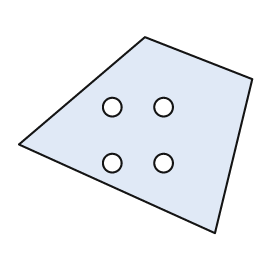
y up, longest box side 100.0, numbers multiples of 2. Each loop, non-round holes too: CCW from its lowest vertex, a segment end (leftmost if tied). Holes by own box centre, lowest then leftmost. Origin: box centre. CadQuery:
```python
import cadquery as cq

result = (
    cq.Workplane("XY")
    .moveTo(34.0, -42.0)
    .lineTo(50.0, 24.0)
    .lineTo(4.0, 42.0)
    .lineTo(-50.0, -4.0)
    .close()
    .moveTo(-10.0, -12.0)
    .circle(4.0)
    .moveTo(12.0, -12.0)
    .circle(4.0)
    .moveTo(-10.0, 12.0)
    .circle(4.0)
    .moveTo(12.0, 12.0)
    .circle(4.0)
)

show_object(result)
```